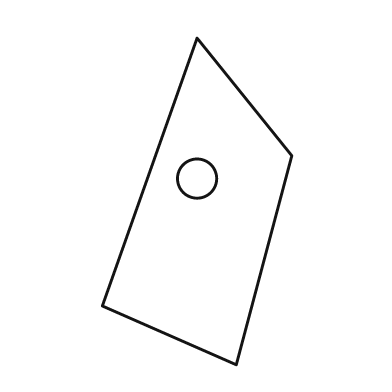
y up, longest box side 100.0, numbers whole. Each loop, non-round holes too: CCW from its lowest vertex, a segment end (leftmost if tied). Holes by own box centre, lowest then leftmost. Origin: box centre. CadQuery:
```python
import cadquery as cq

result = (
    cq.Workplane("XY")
    .moveTo(12.0, -50.0)
    .lineTo(29.0, 14.0)
    .lineTo(0.0, 50.0)
    .lineTo(-29.0, -32.0)
    .close()
    .moveTo(0.0, 7.0)
    .circle(6.0)
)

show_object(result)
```